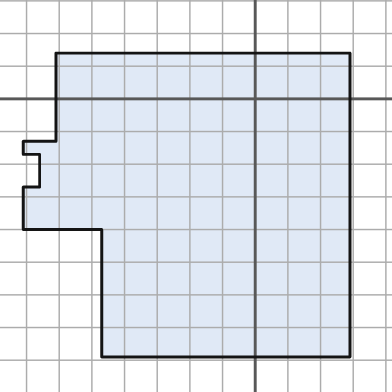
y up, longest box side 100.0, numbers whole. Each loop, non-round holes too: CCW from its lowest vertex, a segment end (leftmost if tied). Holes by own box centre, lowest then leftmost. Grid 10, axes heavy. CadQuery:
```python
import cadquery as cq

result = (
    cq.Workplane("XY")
    .moveTo(-47.0, -79.0)
    .lineTo(29.0, -79.0)
    .lineTo(29.0, 14.0)
    .lineTo(-61.0, 14.0)
    .lineTo(-61.0, -13.0)
    .lineTo(-71.0, -13.0)
    .lineTo(-71.0, -17.0)
    .lineTo(-66.0, -17.0)
    .lineTo(-66.0, -27.0)
    .lineTo(-71.0, -27.0)
    .lineTo(-71.0, -40.0)
    .lineTo(-47.0, -40.0)
    .close()
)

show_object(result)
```